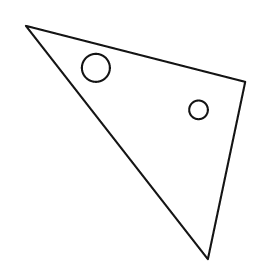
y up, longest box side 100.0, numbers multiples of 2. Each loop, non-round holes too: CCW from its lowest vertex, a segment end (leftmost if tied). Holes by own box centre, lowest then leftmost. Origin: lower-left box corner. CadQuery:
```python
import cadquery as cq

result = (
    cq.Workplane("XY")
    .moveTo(78.0, 0.0)
    .lineTo(94.0, 76.0)
    .lineTo(0.0, 100.0)
    .close()
    .moveTo(74.0, 64.0)
    .circle(4.0)
    .moveTo(30.0, 82.0)
    .circle(6.0)
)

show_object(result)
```